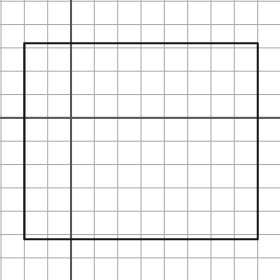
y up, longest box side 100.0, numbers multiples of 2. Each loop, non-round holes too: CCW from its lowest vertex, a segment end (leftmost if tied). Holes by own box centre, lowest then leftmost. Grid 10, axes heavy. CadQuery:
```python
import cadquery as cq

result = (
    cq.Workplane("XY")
    .moveTo(-20.0, -52.0)
    .lineTo(80.0, -52.0)
    .lineTo(80.0, 32.0)
    .lineTo(-20.0, 32.0)
    .close()
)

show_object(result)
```